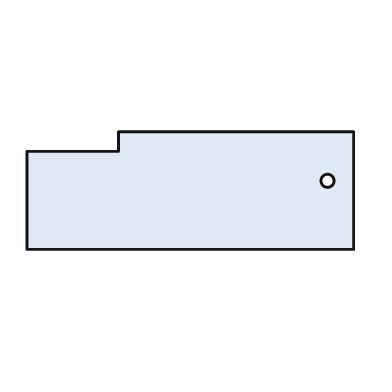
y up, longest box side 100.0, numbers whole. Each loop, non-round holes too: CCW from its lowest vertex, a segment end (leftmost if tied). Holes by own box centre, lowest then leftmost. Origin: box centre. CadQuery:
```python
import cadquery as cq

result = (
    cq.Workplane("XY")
    .moveTo(-50.0, -18.0)
    .lineTo(50.0, -18.0)
    .lineTo(50.0, 18.0)
    .lineTo(-22.0, 18.0)
    .lineTo(-22.0, 12.0)
    .lineTo(-50.0, 12.0)
    .close()
    .moveTo(42.0, 3.0)
    .circle(2.0)
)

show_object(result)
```